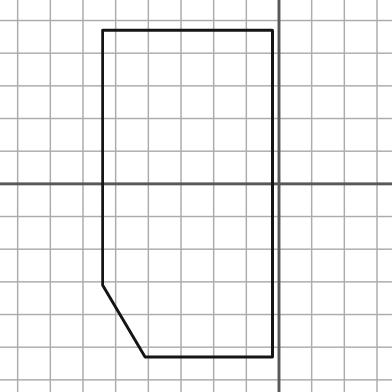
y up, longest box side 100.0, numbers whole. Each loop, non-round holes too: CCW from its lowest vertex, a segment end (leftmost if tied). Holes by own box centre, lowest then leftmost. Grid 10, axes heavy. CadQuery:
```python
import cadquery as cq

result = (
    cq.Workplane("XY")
    .moveTo(-41.0, -53.0)
    .lineTo(-2.0, -53.0)
    .lineTo(-2.0, 47.0)
    .lineTo(-54.0, 47.0)
    .lineTo(-54.0, -31.0)
    .close()
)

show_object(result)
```